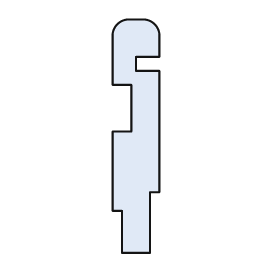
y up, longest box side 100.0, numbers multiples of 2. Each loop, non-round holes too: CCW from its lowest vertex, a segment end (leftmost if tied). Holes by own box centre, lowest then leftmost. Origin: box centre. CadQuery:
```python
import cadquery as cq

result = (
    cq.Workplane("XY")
    .moveTo(-6.0, -50.0)
    .lineTo(6.0, -50.0)
    .lineTo(6.0, -24.0)
    .lineTo(10.0, -24.0)
    .lineTo(10.0, 28.0)
    .lineTo(0.0, 28.0)
    .lineTo(0.0, 34.0)
    .lineTo(10.0, 34.0)
    .lineTo(10.0, 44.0)
    .threePointArc((8.0, 48.0), (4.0, 50.0))
    .lineTo(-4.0, 50.0)
    .threePointArc((-8.0, 48.0), (-10.0, 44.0))
    .lineTo(-10.0, 22.0)
    .lineTo(-2.0, 22.0)
    .lineTo(-2.0, 2.0)
    .lineTo(-10.0, 2.0)
    .lineTo(-10.0, -32.0)
    .lineTo(-6.0, -32.0)
    .close()
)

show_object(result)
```